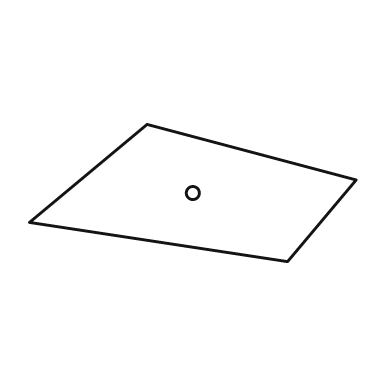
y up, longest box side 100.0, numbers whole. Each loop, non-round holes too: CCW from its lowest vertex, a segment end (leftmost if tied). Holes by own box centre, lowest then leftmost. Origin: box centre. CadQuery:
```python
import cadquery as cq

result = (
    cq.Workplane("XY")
    .moveTo(29.0, -21.0)
    .lineTo(50.0, 4.0)
    .lineTo(-14.0, 21.0)
    .lineTo(-50.0, -9.0)
    .close()
    .moveTo(0.0, 0.0)
    .circle(2.0)
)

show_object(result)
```